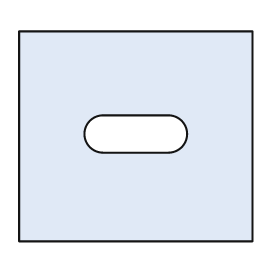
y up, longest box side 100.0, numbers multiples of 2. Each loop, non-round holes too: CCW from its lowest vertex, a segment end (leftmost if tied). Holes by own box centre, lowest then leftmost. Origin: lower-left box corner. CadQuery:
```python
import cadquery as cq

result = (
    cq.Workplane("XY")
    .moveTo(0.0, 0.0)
    .lineTo(100.0, 0.0)
    .lineTo(100.0, 90.0)
    .lineTo(0.0, 90.0)
    .close()
    .moveTo(36.0, 38.0)
    .lineTo(64.0, 38.0)
    .threePointArc((72.0, 46.0), (64.0, 54.0))
    .lineTo(36.0, 54.0)
    .threePointArc((28.0, 46.0), (36.0, 38.0))
    .close()
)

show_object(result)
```